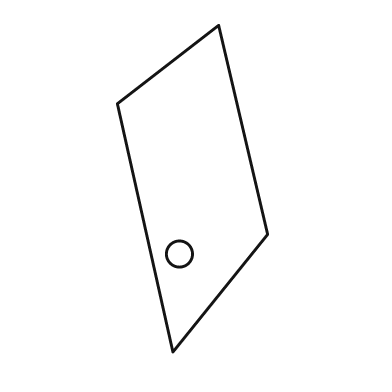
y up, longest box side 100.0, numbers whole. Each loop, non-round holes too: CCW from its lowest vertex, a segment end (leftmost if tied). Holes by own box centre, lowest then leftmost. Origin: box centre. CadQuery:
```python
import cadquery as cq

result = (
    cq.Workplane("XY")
    .moveTo(-6.0, -50.0)
    .lineTo(23.0, -14.0)
    .lineTo(8.0, 50.0)
    .lineTo(-23.0, 26.0)
    .close()
    .moveTo(-4.0, -20.0)
    .circle(4.0)
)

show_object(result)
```